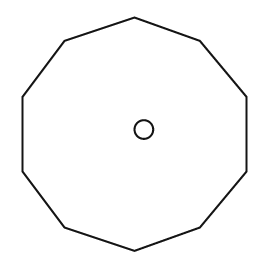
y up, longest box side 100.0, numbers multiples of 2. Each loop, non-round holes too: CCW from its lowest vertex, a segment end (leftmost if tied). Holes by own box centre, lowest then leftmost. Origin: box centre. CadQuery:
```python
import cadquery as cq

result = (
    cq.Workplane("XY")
    .moveTo(0.0, -50.0)
    .lineTo(28.0, -40.0)
    .lineTo(48.0, -16.0)
    .lineTo(48.0, 16.0)
    .lineTo(28.0, 40.0)
    .lineTo(0.0, 50.0)
    .lineTo(-30.0, 40.0)
    .lineTo(-48.0, 16.0)
    .lineTo(-48.0, -16.0)
    .lineTo(-30.0, -40.0)
    .close()
    .moveTo(4.0, 2.0)
    .circle(4.0)
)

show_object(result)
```